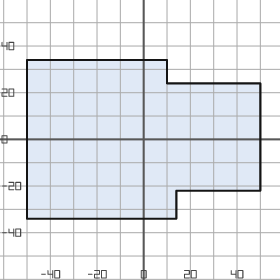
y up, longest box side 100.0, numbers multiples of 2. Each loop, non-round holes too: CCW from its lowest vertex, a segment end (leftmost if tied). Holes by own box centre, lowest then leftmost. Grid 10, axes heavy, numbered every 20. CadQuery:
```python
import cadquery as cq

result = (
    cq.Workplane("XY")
    .moveTo(-50.0, -34.0)
    .lineTo(14.0, -34.0)
    .lineTo(14.0, -22.0)
    .lineTo(50.0, -22.0)
    .lineTo(50.0, 24.0)
    .lineTo(10.0, 24.0)
    .lineTo(10.0, 34.0)
    .lineTo(-50.0, 34.0)
    .close()
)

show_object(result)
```